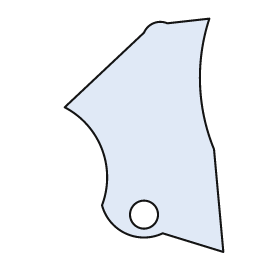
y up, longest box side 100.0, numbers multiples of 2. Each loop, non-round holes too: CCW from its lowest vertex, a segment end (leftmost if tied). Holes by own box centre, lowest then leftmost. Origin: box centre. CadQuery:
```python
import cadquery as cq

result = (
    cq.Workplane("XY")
    .moveTo(34.0, -50.0)
    .lineTo(30.0, -6.0)
    .threePointArc((24.0, 22.0), (28.0, 50.0))
    .lineTo(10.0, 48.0)
    .threePointArc((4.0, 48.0), (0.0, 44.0))
    .lineTo(-34.0, 12.0)
    .threePointArc((-18.0, -6.0), (-18.0, -30.0))
    .threePointArc((-8.0, -42.0), (8.0, -42.0))
    .close()
    .moveTo(0.0, -34.0)
    .circle(6.0)
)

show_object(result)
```